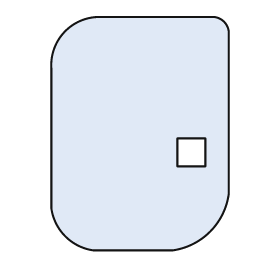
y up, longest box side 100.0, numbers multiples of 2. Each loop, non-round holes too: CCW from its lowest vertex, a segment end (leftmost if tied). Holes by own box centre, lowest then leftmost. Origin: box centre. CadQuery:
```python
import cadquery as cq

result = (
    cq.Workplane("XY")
    .moveTo(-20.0, -50.0)
    .lineTo(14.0, -50.0)
    .threePointArc((30.0, -42.0), (38.0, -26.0))
    .lineTo(38.0, 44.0)
    .threePointArc((36.0, 48.0), (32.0, 50.0))
    .lineTo(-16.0, 50.0)
    .threePointArc((-32.0, 44.0), (-38.0, 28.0))
    .lineTo(-38.0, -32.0)
    .threePointArc((-32.0, -44.0), (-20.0, -50.0))
    .close()
    .moveTo(16.0, -14.0)
    .lineTo(28.0, -14.0)
    .lineTo(28.0, -2.0)
    .lineTo(16.0, -2.0)
    .close()
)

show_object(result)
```